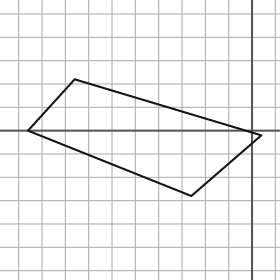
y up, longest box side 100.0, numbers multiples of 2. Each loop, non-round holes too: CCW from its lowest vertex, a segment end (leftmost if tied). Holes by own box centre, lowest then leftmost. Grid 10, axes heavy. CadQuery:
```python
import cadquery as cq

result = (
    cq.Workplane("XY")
    .moveTo(-26.0, -28.0)
    .lineTo(4.0, -2.0)
    .lineTo(-76.0, 22.0)
    .lineTo(-96.0, 0.0)
    .close()
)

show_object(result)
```